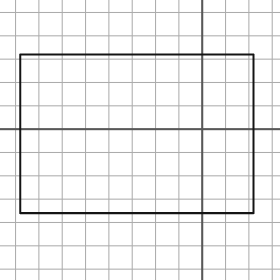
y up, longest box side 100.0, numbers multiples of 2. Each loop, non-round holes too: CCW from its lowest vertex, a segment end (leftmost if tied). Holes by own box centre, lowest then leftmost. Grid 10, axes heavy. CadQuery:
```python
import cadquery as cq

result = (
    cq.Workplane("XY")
    .moveTo(-78.0, -36.0)
    .lineTo(22.0, -36.0)
    .lineTo(22.0, 32.0)
    .lineTo(-78.0, 32.0)
    .close()
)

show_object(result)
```